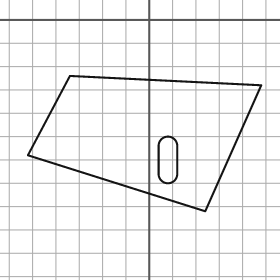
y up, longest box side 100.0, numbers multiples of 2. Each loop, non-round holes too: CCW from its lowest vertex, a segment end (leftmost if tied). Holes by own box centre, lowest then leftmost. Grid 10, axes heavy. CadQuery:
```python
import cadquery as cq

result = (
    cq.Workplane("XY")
    .moveTo(24.0, -82.0)
    .lineTo(48.0, -28.0)
    .lineTo(-34.0, -24.0)
    .lineTo(-52.0, -58.0)
    .close()
    .moveTo(4.0, -66.0)
    .threePointArc((8.0, -70.0), (12.0, -66.0))
    .lineTo(12.0, -54.0)
    .threePointArc((8.0, -50.0), (4.0, -54.0))
    .close()
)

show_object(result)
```